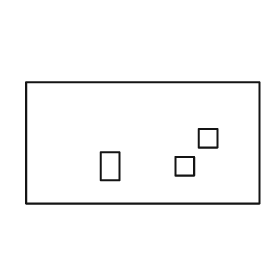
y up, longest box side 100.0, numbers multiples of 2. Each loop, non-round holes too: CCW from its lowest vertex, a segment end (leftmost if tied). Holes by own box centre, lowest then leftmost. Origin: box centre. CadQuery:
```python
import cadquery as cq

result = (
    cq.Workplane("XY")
    .moveTo(-50.0, -26.0)
    .lineTo(50.0, -26.0)
    .lineTo(50.0, 26.0)
    .lineTo(-50.0, 26.0)
    .close()
    .moveTo(-18.0, -16.0)
    .lineTo(-10.0, -16.0)
    .lineTo(-10.0, -4.0)
    .lineTo(-18.0, -4.0)
    .close()
    .moveTo(14.0, -14.0)
    .lineTo(22.0, -14.0)
    .lineTo(22.0, -6.0)
    .lineTo(14.0, -6.0)
    .close()
    .moveTo(24.0, -2.0)
    .lineTo(32.0, -2.0)
    .lineTo(32.0, 6.0)
    .lineTo(24.0, 6.0)
    .close()
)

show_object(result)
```